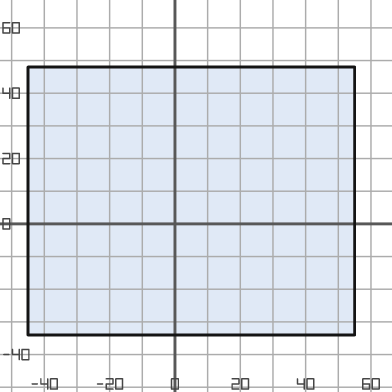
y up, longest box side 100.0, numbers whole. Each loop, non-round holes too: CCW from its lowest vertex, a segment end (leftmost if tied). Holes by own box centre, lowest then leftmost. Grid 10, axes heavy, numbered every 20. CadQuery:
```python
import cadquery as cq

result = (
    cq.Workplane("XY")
    .moveTo(-45.0, -34.0)
    .lineTo(55.0, -34.0)
    .lineTo(55.0, 48.0)
    .lineTo(-45.0, 48.0)
    .close()
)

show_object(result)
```